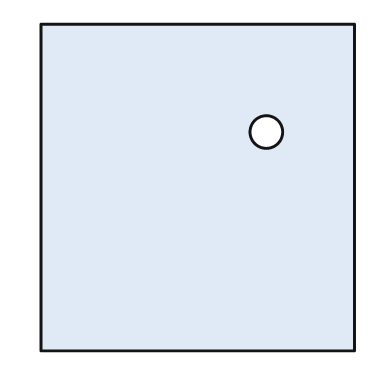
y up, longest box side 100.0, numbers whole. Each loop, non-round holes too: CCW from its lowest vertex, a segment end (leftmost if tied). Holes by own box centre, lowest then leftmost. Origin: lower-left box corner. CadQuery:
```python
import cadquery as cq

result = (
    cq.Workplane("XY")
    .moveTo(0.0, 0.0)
    .lineTo(96.0, 0.0)
    .lineTo(96.0, 100.0)
    .lineTo(0.0, 100.0)
    .close()
    .moveTo(69.0, 67.0)
    .circle(5.0)
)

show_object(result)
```